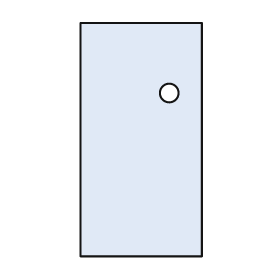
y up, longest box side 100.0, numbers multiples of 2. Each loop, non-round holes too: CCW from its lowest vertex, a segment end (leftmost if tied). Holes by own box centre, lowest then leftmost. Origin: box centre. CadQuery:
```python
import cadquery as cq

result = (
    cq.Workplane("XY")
    .moveTo(-26.0, -50.0)
    .lineTo(26.0, -50.0)
    .lineTo(26.0, 50.0)
    .lineTo(-26.0, 50.0)
    .close()
    .moveTo(12.0, 20.0)
    .circle(4.0)
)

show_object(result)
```